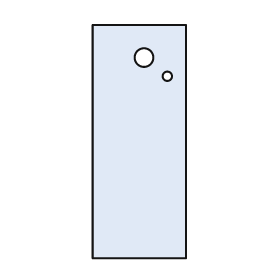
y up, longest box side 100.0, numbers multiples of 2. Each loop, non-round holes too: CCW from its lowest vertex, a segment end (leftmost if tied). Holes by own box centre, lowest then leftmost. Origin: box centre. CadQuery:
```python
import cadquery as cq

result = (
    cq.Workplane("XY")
    .moveTo(-20.0, -50.0)
    .lineTo(20.0, -50.0)
    .lineTo(20.0, 50.0)
    .lineTo(-20.0, 50.0)
    .close()
    .moveTo(12.0, 28.0)
    .circle(2.0)
    .moveTo(2.0, 36.0)
    .circle(4.0)
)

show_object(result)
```